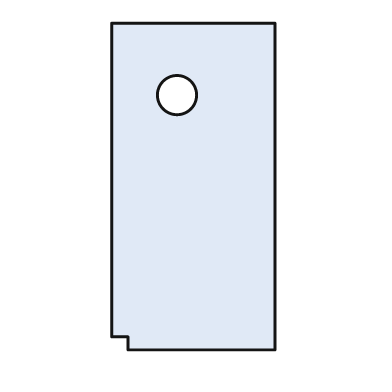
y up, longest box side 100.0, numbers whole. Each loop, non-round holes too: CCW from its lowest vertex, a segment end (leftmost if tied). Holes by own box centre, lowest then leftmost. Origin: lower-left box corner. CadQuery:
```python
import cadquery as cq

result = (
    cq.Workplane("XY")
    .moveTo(5.0, 0.0)
    .lineTo(50.0, 0.0)
    .lineTo(50.0, 100.0)
    .lineTo(0.0, 100.0)
    .lineTo(0.0, 4.0)
    .lineTo(5.0, 4.0)
    .close()
    .moveTo(20.0, 78.0)
    .circle(6.0)
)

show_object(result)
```